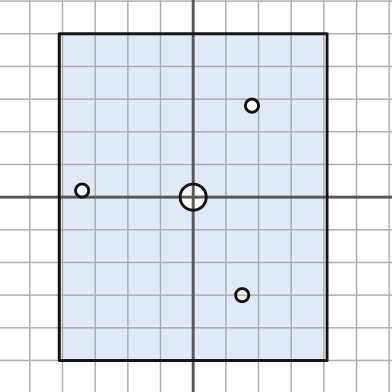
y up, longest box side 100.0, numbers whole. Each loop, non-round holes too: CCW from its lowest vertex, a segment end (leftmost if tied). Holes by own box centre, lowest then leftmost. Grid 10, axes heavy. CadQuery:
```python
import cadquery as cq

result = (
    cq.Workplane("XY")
    .moveTo(-41.0, -50.0)
    .lineTo(41.0, -50.0)
    .lineTo(41.0, 50.0)
    .lineTo(-41.0, 50.0)
    .close()
    .moveTo(15.0, -30.0)
    .circle(2.0)
    .moveTo(0.0, 0.0)
    .circle(4.0)
    .moveTo(-34.0, 2.0)
    .circle(2.0)
    .moveTo(18.0, 28.0)
    .circle(2.0)
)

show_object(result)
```